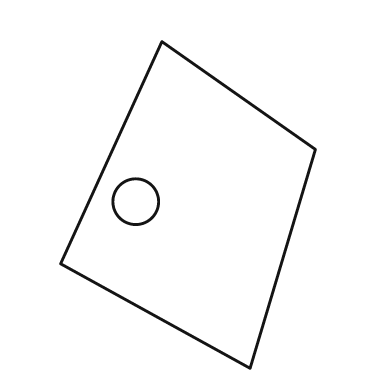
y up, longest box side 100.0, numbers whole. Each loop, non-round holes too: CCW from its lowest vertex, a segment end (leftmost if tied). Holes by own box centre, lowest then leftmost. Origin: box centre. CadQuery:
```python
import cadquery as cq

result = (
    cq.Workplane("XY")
    .moveTo(19.0, -50.0)
    .lineTo(39.0, 17.0)
    .lineTo(-8.0, 50.0)
    .lineTo(-39.0, -18.0)
    .close()
    .moveTo(-16.0, 1.0)
    .circle(7.0)
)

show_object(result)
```